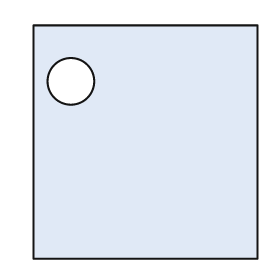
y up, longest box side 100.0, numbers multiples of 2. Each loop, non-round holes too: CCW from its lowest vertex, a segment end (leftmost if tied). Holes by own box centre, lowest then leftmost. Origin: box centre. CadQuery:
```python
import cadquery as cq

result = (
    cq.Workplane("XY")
    .moveTo(-48.0, -50.0)
    .lineTo(48.0, -50.0)
    .lineTo(48.0, 50.0)
    .lineTo(-48.0, 50.0)
    .close()
    .moveTo(-32.0, 26.0)
    .circle(10.0)
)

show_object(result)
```